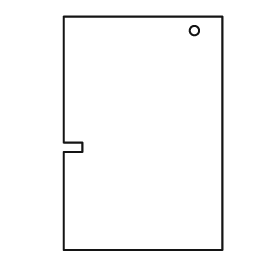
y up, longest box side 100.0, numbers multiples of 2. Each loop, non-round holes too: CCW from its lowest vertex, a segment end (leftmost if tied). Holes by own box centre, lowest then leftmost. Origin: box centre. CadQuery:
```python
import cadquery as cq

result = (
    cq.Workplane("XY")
    .moveTo(-34.0, -50.0)
    .lineTo(34.0, -50.0)
    .lineTo(34.0, 50.0)
    .lineTo(-34.0, 50.0)
    .lineTo(-34.0, -4.0)
    .lineTo(-26.0, -4.0)
    .lineTo(-26.0, -8.0)
    .lineTo(-34.0, -8.0)
    .close()
    .moveTo(22.0, 44.0)
    .circle(2.0)
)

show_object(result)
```